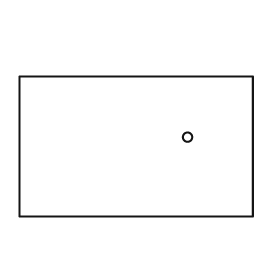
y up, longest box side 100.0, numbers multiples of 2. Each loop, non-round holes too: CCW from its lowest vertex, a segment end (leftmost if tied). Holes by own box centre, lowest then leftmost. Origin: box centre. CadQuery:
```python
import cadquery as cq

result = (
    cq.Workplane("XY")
    .moveTo(-50.0, -30.0)
    .lineTo(50.0, -30.0)
    .lineTo(50.0, 30.0)
    .lineTo(-50.0, 30.0)
    .close()
    .moveTo(22.0, 4.0)
    .circle(2.0)
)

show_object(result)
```